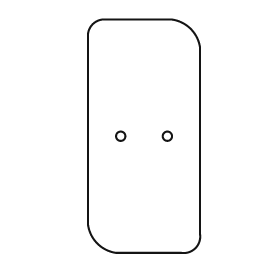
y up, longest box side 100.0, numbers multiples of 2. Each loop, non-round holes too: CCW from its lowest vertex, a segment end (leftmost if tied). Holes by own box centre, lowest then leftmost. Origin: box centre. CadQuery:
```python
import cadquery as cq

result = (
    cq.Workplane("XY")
    .moveTo(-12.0, -50.0)
    .lineTo(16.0, -50.0)
    .threePointArc((22.0, -48.0), (24.0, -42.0))
    .lineTo(24.0, 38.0)
    .threePointArc((20.0, 46.0), (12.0, 50.0))
    .lineTo(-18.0, 50.0)
    .threePointArc((-22.0, 48.0), (-24.0, 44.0))
    .lineTo(-24.0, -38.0)
    .threePointArc((-20.0, -46.0), (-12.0, -50.0))
    .close()
    .moveTo(-10.0, 0.0)
    .circle(2.0)
    .moveTo(10.0, 0.0)
    .circle(2.0)
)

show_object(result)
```